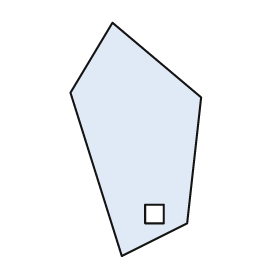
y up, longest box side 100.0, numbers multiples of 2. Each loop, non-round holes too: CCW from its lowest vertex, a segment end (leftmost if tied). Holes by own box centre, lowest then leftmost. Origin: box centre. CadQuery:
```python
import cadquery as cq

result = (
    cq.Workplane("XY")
    .moveTo(-6.0, -50.0)
    .lineTo(22.0, -36.0)
    .lineTo(28.0, 18.0)
    .lineTo(-10.0, 50.0)
    .lineTo(-28.0, 20.0)
    .close()
    .moveTo(4.0, -36.0)
    .lineTo(12.0, -36.0)
    .lineTo(12.0, -28.0)
    .lineTo(4.0, -28.0)
    .close()
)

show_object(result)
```